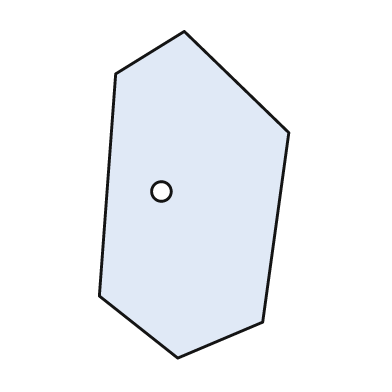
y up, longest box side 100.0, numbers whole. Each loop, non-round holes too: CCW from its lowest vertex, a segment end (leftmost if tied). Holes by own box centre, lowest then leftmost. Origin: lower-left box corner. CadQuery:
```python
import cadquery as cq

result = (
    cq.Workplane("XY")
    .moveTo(24.0, 0.0)
    .lineTo(50.0, 11.0)
    .lineTo(58.0, 69.0)
    .lineTo(26.0, 100.0)
    .lineTo(5.0, 87.0)
    .lineTo(0.0, 19.0)
    .close()
    .moveTo(19.0, 51.0)
    .circle(3.0)
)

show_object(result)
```